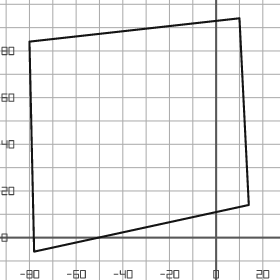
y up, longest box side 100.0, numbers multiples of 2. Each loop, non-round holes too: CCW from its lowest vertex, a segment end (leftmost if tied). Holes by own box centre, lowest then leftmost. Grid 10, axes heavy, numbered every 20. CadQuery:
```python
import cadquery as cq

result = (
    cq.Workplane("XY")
    .moveTo(-78.0, -6.0)
    .lineTo(14.0, 14.0)
    .lineTo(10.0, 94.0)
    .lineTo(-80.0, 84.0)
    .close()
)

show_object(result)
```